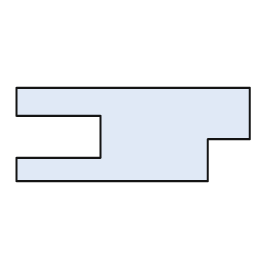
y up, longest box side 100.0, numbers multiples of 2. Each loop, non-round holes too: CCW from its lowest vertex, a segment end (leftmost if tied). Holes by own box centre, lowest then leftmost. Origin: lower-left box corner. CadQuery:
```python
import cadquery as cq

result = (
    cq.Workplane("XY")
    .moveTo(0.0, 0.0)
    .lineTo(82.0, 0.0)
    .lineTo(82.0, 18.0)
    .lineTo(100.0, 18.0)
    .lineTo(100.0, 40.0)
    .lineTo(0.0, 40.0)
    .lineTo(0.0, 28.0)
    .lineTo(36.0, 28.0)
    .lineTo(36.0, 10.0)
    .lineTo(0.0, 10.0)
    .close()
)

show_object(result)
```